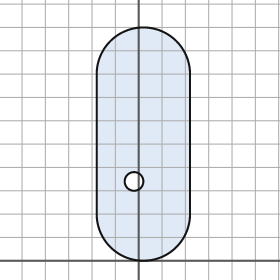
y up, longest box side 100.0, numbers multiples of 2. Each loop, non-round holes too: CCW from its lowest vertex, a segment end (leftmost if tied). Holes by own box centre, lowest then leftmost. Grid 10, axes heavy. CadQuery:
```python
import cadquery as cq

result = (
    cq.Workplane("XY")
    .moveTo(-18.0, 20.0)
    .threePointArc((2.0, 0.0), (22.0, 20.0))
    .lineTo(22.0, 80.0)
    .threePointArc((2.0, 100.0), (-18.0, 80.0))
    .close()
    .moveTo(-2.0, 34.0)
    .circle(4.0)
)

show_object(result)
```